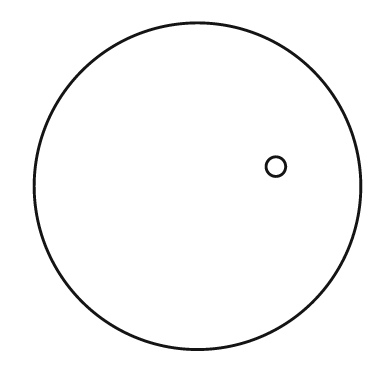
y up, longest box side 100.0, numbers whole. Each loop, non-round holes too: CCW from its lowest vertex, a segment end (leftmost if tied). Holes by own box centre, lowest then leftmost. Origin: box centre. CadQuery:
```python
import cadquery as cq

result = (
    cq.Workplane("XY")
    .moveTo(0.0, 0.0)
    .circle(50.0)
    .moveTo(24.0, 6.0)
    .circle(3.0)
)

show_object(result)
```